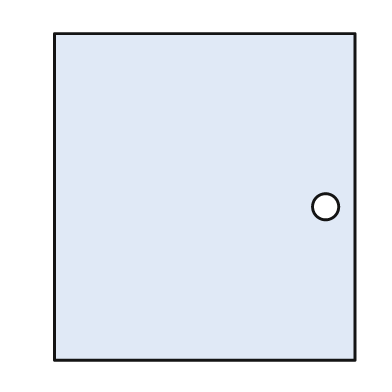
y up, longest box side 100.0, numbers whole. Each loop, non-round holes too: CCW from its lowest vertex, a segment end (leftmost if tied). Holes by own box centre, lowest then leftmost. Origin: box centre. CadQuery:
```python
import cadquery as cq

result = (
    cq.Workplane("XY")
    .moveTo(-46.0, -50.0)
    .lineTo(46.0, -50.0)
    .lineTo(46.0, 50.0)
    .lineTo(-46.0, 50.0)
    .close()
    .moveTo(37.0, -3.0)
    .circle(4.0)
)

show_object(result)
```